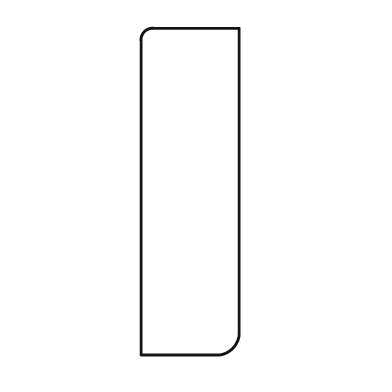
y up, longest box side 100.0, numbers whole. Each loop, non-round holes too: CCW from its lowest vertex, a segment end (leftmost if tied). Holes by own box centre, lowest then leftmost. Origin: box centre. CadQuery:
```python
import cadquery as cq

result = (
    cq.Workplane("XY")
    .moveTo(-15.0, -50.0)
    .lineTo(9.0, -50.0)
    .threePointArc((13.0, -48.0), (15.0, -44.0))
    .lineTo(15.0, 50.0)
    .lineTo(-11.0, 50.0)
    .threePointArc((-14.0, 49.0), (-15.0, 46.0))
    .close()
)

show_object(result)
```